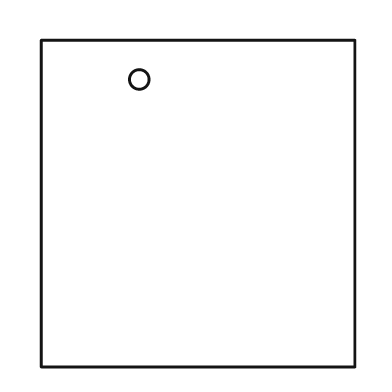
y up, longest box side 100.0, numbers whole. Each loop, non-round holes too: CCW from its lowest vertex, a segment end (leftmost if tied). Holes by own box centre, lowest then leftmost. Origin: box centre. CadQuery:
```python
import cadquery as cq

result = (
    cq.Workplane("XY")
    .moveTo(-48.0, -50.0)
    .lineTo(48.0, -50.0)
    .lineTo(48.0, 50.0)
    .lineTo(-48.0, 50.0)
    .close()
    .moveTo(-18.0, 38.0)
    .circle(3.0)
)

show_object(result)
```